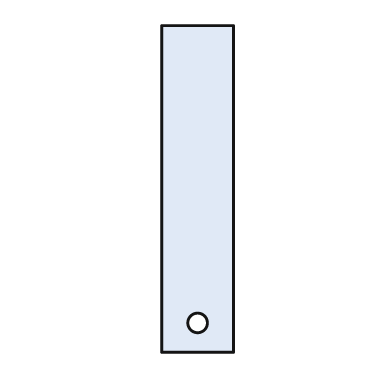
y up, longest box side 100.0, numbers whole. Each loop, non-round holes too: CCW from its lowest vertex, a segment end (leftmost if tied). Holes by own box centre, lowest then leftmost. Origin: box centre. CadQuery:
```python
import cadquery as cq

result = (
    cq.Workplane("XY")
    .moveTo(-11.0, -50.0)
    .lineTo(11.0, -50.0)
    .lineTo(11.0, 50.0)
    .lineTo(-11.0, 50.0)
    .close()
    .moveTo(0.0, -41.0)
    .circle(3.0)
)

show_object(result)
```